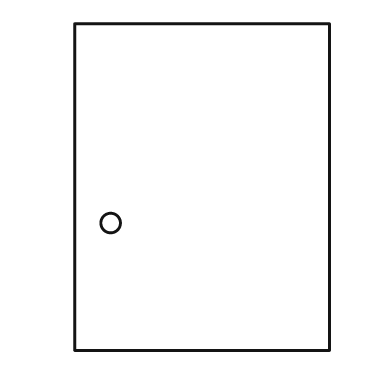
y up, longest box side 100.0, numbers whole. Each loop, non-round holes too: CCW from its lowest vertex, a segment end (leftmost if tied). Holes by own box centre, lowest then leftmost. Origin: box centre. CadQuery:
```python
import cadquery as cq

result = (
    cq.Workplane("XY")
    .moveTo(-39.0, -50.0)
    .lineTo(39.0, -50.0)
    .lineTo(39.0, 50.0)
    .lineTo(-39.0, 50.0)
    .close()
    .moveTo(-28.0, -11.0)
    .circle(3.0)
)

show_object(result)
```